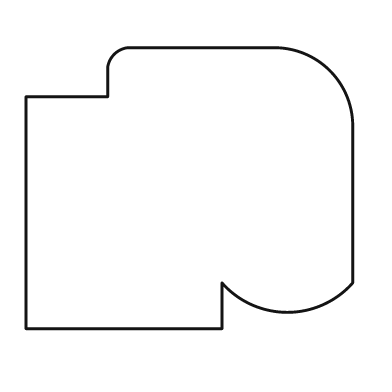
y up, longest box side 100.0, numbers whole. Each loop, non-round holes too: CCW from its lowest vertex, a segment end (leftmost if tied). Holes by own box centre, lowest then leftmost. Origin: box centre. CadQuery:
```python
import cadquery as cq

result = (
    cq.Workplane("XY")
    .moveTo(-50.0, -43.0)
    .lineTo(10.0, -43.0)
    .lineTo(10.0, -29.0)
    .threePointArc((30.0, -38.0), (50.0, -29.0))
    .lineTo(50.0, 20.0)
    .threePointArc((43.0, 36.0), (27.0, 43.0))
    .lineTo(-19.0, 43.0)
    .threePointArc((-23.0, 41.0), (-25.0, 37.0))
    .lineTo(-25.0, 28.0)
    .lineTo(-50.0, 28.0)
    .close()
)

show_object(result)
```